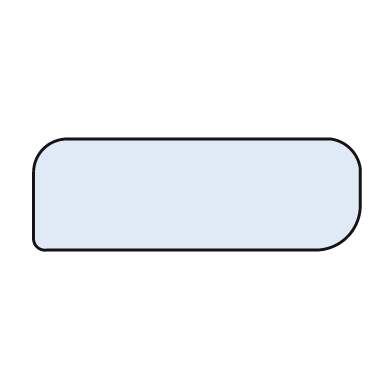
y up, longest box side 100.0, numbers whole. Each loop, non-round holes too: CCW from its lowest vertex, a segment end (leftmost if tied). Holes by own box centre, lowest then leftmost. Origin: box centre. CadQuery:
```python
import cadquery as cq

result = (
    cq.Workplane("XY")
    .moveTo(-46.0, -17.0)
    .lineTo(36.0, -17.0)
    .threePointArc((46.0, -13.0), (50.0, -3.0))
    .lineTo(50.0, 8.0)
    .threePointArc((47.0, 14.0), (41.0, 17.0))
    .lineTo(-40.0, 17.0)
    .threePointArc((-47.0, 14.0), (-50.0, 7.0))
    .lineTo(-50.0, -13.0)
    .threePointArc((-49.0, -16.0), (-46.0, -17.0))
    .close()
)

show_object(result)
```